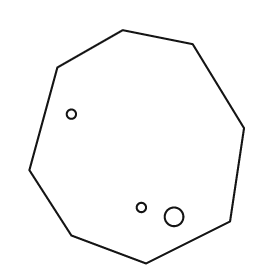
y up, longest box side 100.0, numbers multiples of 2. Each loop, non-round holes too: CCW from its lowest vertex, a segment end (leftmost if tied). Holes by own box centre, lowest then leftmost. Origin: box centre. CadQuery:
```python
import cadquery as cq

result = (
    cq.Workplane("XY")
    .moveTo(4.0, -50.0)
    .lineTo(40.0, -32.0)
    .lineTo(46.0, 8.0)
    .lineTo(24.0, 44.0)
    .lineTo(-6.0, 50.0)
    .lineTo(-34.0, 34.0)
    .lineTo(-46.0, -10.0)
    .lineTo(-28.0, -38.0)
    .close()
    .moveTo(16.0, -30.0)
    .circle(4.0)
    .moveTo(2.0, -26.0)
    .circle(2.0)
    .moveTo(-28.0, 14.0)
    .circle(2.0)
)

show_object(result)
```